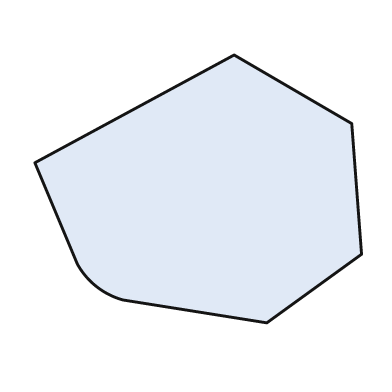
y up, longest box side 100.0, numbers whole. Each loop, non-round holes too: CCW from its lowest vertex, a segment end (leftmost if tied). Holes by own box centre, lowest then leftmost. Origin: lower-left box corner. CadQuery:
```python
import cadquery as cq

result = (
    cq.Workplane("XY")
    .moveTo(71.0, 0.0)
    .lineTo(100.0, 21.0)
    .lineTo(97.0, 61.0)
    .lineTo(61.0, 82.0)
    .lineTo(0.0, 49.0)
    .lineTo(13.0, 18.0)
    .threePointArc((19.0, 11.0), (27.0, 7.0))
    .close()
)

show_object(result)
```